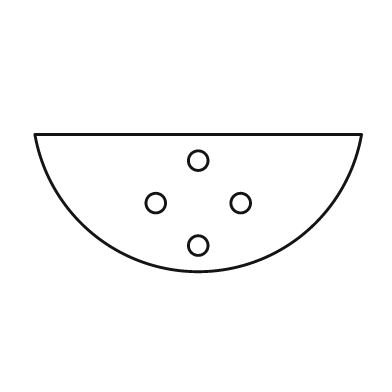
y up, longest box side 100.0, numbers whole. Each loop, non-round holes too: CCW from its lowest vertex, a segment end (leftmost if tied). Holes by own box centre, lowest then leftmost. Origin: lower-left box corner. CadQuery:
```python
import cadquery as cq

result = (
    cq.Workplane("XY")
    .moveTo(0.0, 42.0)
    .threePointArc((50.0, 0.0), (100.0, 42.0))
    .close()
    .moveTo(50.0, 8.0)
    .circle(3.0)
    .moveTo(37.0, 21.0)
    .circle(3.0)
    .moveTo(63.0, 21.0)
    .circle(3.0)
    .moveTo(50.0, 34.0)
    .circle(3.0)
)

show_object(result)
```